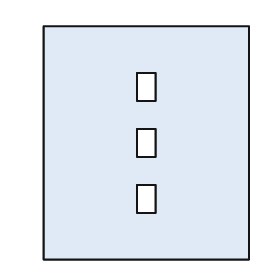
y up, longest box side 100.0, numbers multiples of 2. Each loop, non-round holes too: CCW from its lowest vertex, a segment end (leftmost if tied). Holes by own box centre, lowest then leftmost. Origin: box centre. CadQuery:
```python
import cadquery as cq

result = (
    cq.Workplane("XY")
    .moveTo(-44.0, -50.0)
    .lineTo(44.0, -50.0)
    .lineTo(44.0, 50.0)
    .lineTo(-44.0, 50.0)
    .close()
    .moveTo(-4.0, -30.0)
    .lineTo(4.0, -30.0)
    .lineTo(4.0, -18.0)
    .lineTo(-4.0, -18.0)
    .close()
    .moveTo(-4.0, -6.0)
    .lineTo(4.0, -6.0)
    .lineTo(4.0, 6.0)
    .lineTo(-4.0, 6.0)
    .close()
    .moveTo(-4.0, 18.0)
    .lineTo(4.0, 18.0)
    .lineTo(4.0, 30.0)
    .lineTo(-4.0, 30.0)
    .close()
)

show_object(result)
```